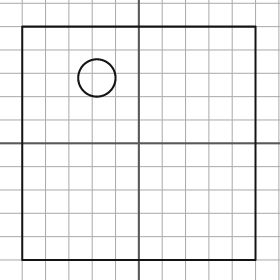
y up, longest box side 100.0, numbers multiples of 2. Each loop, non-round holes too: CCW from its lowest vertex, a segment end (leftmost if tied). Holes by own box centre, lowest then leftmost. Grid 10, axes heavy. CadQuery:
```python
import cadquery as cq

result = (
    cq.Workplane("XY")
    .moveTo(-50.0, -50.0)
    .lineTo(50.0, -50.0)
    .lineTo(50.0, 50.0)
    .lineTo(-50.0, 50.0)
    .close()
    .moveTo(-18.0, 28.0)
    .circle(8.0)
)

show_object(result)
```